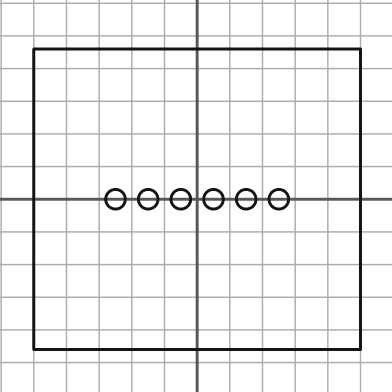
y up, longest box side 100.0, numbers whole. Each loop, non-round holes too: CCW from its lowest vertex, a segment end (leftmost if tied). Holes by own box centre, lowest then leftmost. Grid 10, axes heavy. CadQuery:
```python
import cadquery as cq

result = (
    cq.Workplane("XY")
    .moveTo(-50.0, -46.0)
    .lineTo(50.0, -46.0)
    .lineTo(50.0, 46.0)
    .lineTo(-50.0, 46.0)
    .close()
    .moveTo(-25.0, 0.0)
    .circle(3.0)
    .moveTo(-15.0, 0.0)
    .circle(3.0)
    .moveTo(-5.0, 0.0)
    .circle(3.0)
    .moveTo(5.0, 0.0)
    .circle(3.0)
    .moveTo(15.0, 0.0)
    .circle(3.0)
    .moveTo(25.0, 0.0)
    .circle(3.0)
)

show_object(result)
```